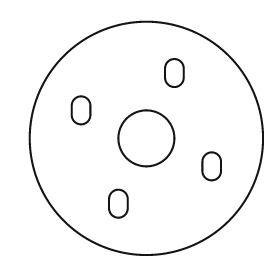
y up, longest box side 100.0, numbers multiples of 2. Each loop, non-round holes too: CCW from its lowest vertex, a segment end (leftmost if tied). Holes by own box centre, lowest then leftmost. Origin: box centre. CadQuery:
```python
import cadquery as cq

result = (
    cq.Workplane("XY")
    .moveTo(0.0, 0.0)
    .circle(50.0)
    .moveTo(-16.0, -30.0)
    .threePointArc((-12.0, -34.0), (-8.0, -30.0))
    .lineTo(-8.0, -26.0)
    .threePointArc((-12.0, -22.0), (-16.0, -26.0))
    .close()
    .moveTo(24.0, -14.0)
    .threePointArc((28.0, -18.0), (32.0, -14.0))
    .lineTo(32.0, -10.0)
    .threePointArc((28.0, -6.0), (24.0, -10.0))
    .close()
    .moveTo(0.0, 0.0)
    .circle(12.0)
    .moveTo(-32.0, 10.0)
    .threePointArc((-28.0, 6.0), (-24.0, 10.0))
    .lineTo(-24.0, 14.0)
    .threePointArc((-28.0, 18.0), (-32.0, 14.0))
    .close()
    .moveTo(8.0, 26.0)
    .threePointArc((12.0, 22.0), (16.0, 26.0))
    .lineTo(16.0, 30.0)
    .threePointArc((12.0, 34.0), (8.0, 30.0))
    .close()
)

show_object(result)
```